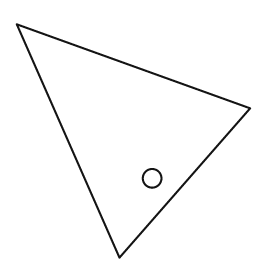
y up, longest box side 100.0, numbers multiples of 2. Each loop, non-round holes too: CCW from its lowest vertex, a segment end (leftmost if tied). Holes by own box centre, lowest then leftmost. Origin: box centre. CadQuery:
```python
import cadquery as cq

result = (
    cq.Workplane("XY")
    .moveTo(-6.0, -50.0)
    .lineTo(50.0, 14.0)
    .lineTo(-50.0, 50.0)
    .close()
    .moveTo(8.0, -16.0)
    .circle(4.0)
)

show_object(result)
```